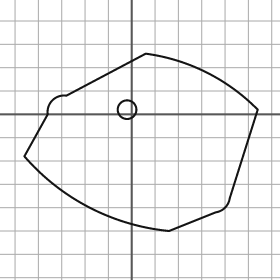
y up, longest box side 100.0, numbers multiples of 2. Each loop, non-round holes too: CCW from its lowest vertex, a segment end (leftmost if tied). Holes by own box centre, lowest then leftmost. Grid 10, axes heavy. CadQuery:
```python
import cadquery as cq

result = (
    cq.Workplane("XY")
    .moveTo(16.0, -50.0)
    .lineTo(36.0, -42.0)
    .threePointArc((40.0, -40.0), (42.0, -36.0))
    .lineTo(54.0, 2.0)
    .threePointArc((32.0, 18.0), (6.0, 26.0))
    .lineTo(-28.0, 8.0)
    .threePointArc((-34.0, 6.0), (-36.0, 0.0))
    .lineTo(-46.0, -18.0)
    .threePointArc((-18.0, -40.0), (16.0, -50.0))
    .close()
    .moveTo(-2.0, 2.0)
    .circle(4.0)
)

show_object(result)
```